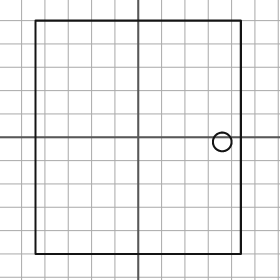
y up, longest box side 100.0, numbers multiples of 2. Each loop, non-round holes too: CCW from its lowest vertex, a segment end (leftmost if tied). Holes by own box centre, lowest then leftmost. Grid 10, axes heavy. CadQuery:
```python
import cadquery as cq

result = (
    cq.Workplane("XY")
    .moveTo(-44.0, -50.0)
    .lineTo(44.0, -50.0)
    .lineTo(44.0, 50.0)
    .lineTo(-44.0, 50.0)
    .close()
    .moveTo(36.0, -2.0)
    .circle(4.0)
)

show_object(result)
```